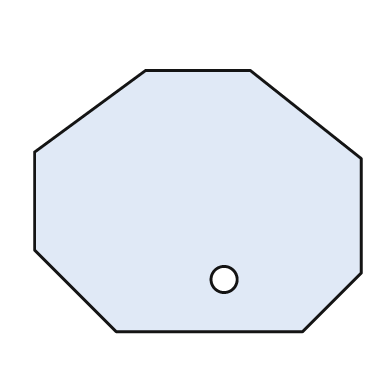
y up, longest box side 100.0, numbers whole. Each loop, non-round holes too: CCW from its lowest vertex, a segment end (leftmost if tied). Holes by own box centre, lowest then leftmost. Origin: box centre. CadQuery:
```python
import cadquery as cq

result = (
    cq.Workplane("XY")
    .moveTo(-25.0, -40.0)
    .lineTo(32.0, -40.0)
    .lineTo(50.0, -22.0)
    .lineTo(50.0, 13.0)
    .lineTo(16.0, 40.0)
    .lineTo(-16.0, 40.0)
    .lineTo(-50.0, 15.0)
    .lineTo(-50.0, -15.0)
    .close()
    .moveTo(8.0, -24.0)
    .circle(4.0)
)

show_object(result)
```